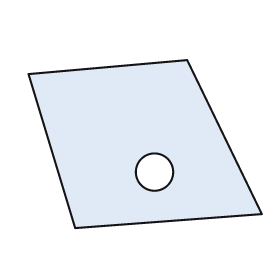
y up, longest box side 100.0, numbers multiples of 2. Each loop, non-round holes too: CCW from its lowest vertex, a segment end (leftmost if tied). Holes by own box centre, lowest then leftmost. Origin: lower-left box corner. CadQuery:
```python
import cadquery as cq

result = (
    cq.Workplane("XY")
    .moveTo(20.0, 0.0)
    .lineTo(100.0, 6.0)
    .lineTo(68.0, 72.0)
    .lineTo(0.0, 66.0)
    .close()
    .moveTo(54.0, 24.0)
    .circle(8.0)
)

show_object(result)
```